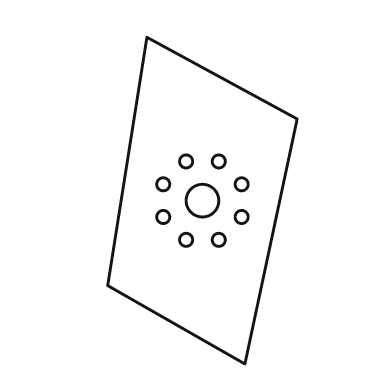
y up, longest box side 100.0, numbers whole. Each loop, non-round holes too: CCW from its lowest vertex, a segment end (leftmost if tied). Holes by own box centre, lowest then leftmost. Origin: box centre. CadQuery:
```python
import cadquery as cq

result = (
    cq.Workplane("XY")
    .moveTo(13.0, -50.0)
    .lineTo(29.0, 25.0)
    .lineTo(-17.0, 50.0)
    .lineTo(-29.0, -26.0)
    .close()
    .moveTo(-5.0, -12.0)
    .circle(2.0)
    .moveTo(5.0, -12.0)
    .circle(2.0)
    .moveTo(-12.0, -5.0)
    .circle(2.0)
    .moveTo(12.0, -5.0)
    .circle(2.0)
    .moveTo(0.0, 0.0)
    .circle(5.0)
    .moveTo(-12.0, 5.0)
    .circle(2.0)
    .moveTo(12.0, 5.0)
    .circle(2.0)
    .moveTo(-5.0, 12.0)
    .circle(2.0)
    .moveTo(5.0, 12.0)
    .circle(2.0)
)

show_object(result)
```